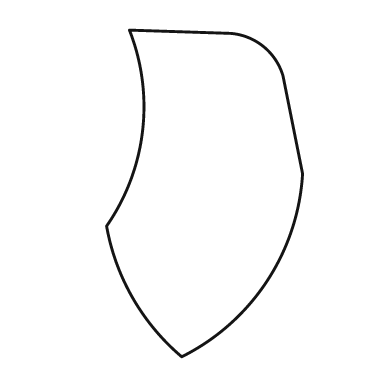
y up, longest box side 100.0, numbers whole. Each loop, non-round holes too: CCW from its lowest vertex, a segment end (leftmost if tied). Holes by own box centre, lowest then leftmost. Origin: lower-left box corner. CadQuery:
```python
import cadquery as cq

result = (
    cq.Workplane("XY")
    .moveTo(23.0, 0.0)
    .threePointArc((49.0, 23.0), (60.0, 56.0))
    .lineTo(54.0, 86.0)
    .threePointArc((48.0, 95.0), (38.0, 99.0))
    .lineTo(7.0, 100.0)
    .threePointArc((11.0, 69.0), (0.0, 40.0))
    .threePointArc((8.0, 18.0), (23.0, 0.0))
    .close()
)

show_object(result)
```